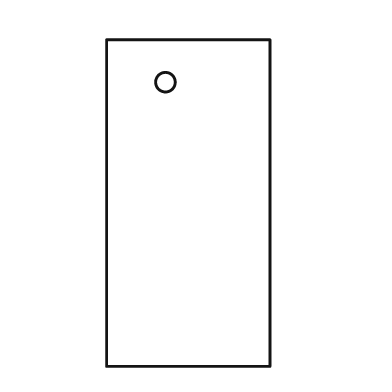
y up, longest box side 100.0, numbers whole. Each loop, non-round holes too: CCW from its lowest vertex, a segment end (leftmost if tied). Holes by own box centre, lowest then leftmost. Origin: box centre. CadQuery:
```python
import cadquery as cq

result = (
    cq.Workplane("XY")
    .moveTo(-25.0, -50.0)
    .lineTo(25.0, -50.0)
    .lineTo(25.0, 50.0)
    .lineTo(-25.0, 50.0)
    .close()
    .moveTo(-7.0, 37.0)
    .circle(3.0)
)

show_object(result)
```